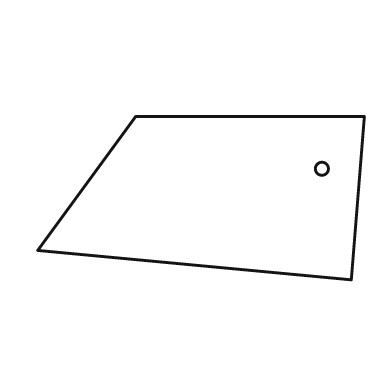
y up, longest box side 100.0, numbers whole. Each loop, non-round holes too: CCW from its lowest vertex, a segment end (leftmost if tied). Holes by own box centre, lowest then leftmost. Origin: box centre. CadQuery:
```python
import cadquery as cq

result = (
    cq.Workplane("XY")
    .moveTo(46.0, -25.0)
    .lineTo(50.0, 25.0)
    .lineTo(-20.0, 25.0)
    .lineTo(-50.0, -16.0)
    .close()
    .moveTo(37.0, 9.0)
    .circle(2.0)
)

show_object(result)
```